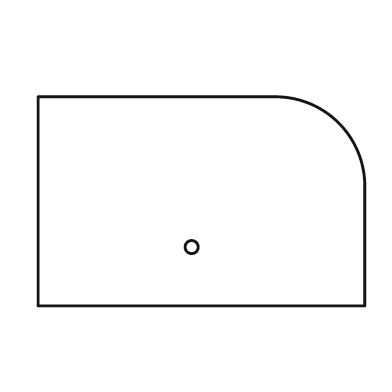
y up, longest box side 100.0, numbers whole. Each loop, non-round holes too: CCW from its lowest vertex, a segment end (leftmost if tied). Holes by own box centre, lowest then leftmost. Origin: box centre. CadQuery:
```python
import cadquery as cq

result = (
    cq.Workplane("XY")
    .moveTo(-50.0, -32.0)
    .lineTo(50.0, -32.0)
    .lineTo(50.0, 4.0)
    .threePointArc((42.0, 24.0), (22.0, 32.0))
    .lineTo(-50.0, 32.0)
    .close()
    .moveTo(-3.0, -14.0)
    .circle(2.0)
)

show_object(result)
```